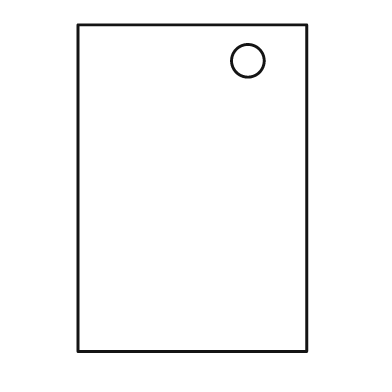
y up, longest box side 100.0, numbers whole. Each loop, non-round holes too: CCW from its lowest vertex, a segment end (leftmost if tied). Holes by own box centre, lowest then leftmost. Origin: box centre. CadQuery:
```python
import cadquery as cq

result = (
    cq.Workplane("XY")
    .moveTo(-35.0, -50.0)
    .lineTo(35.0, -50.0)
    .lineTo(35.0, 50.0)
    .lineTo(-35.0, 50.0)
    .close()
    .moveTo(17.0, 39.0)
    .circle(5.0)
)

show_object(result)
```